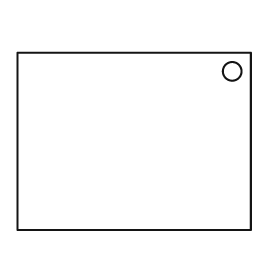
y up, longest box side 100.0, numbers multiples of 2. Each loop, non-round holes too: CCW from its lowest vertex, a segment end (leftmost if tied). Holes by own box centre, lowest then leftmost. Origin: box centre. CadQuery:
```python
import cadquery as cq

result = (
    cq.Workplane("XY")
    .moveTo(-50.0, -38.0)
    .lineTo(50.0, -38.0)
    .lineTo(50.0, 38.0)
    .lineTo(-50.0, 38.0)
    .close()
    .moveTo(42.0, 30.0)
    .circle(4.0)
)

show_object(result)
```